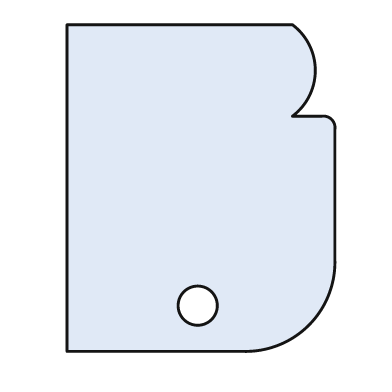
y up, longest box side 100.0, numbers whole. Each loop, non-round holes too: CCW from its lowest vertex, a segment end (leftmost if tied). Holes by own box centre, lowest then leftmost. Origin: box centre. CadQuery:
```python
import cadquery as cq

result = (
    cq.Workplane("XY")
    .moveTo(-41.0, -50.0)
    .lineTo(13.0, -50.0)
    .threePointArc((33.0, -42.0), (41.0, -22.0))
    .lineTo(41.0, 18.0)
    .threePointArc((40.0, 21.0), (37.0, 22.0))
    .lineTo(28.0, 22.0)
    .threePointArc((35.0, 36.0), (28.0, 50.0))
    .lineTo(-41.0, 50.0)
    .close()
    .moveTo(-1.0, -36.0)
    .circle(6.0)
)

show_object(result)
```